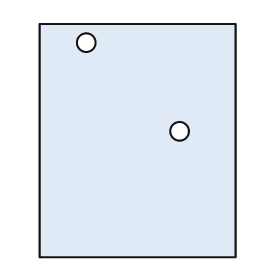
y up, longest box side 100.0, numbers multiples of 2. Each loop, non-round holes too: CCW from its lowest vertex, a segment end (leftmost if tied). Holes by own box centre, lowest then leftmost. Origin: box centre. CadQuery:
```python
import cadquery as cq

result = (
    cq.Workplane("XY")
    .moveTo(-42.0, -50.0)
    .lineTo(42.0, -50.0)
    .lineTo(42.0, 50.0)
    .lineTo(-42.0, 50.0)
    .close()
    .moveTo(18.0, 4.0)
    .circle(4.0)
    .moveTo(-22.0, 42.0)
    .circle(4.0)
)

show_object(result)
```